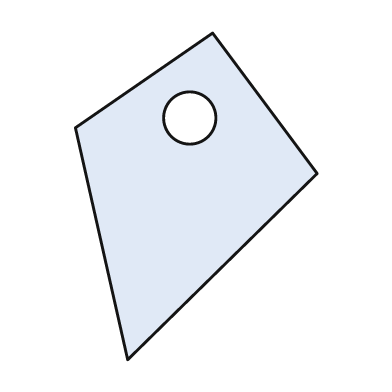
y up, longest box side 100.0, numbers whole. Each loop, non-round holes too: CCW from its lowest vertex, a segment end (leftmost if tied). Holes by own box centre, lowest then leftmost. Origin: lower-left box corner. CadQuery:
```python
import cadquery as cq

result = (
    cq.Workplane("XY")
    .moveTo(16.0, 0.0)
    .lineTo(74.0, 57.0)
    .lineTo(42.0, 100.0)
    .lineTo(0.0, 71.0)
    .close()
    .moveTo(35.0, 74.0)
    .circle(8.0)
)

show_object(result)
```